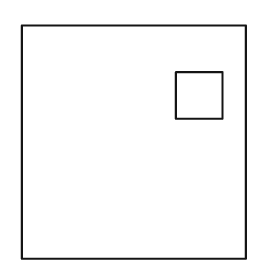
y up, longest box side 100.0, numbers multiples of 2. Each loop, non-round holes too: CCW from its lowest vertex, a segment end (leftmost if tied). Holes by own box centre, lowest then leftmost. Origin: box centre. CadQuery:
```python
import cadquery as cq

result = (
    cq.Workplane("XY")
    .moveTo(-48.0, -50.0)
    .lineTo(48.0, -50.0)
    .lineTo(48.0, 50.0)
    .lineTo(-48.0, 50.0)
    .close()
    .moveTo(18.0, 10.0)
    .lineTo(38.0, 10.0)
    .lineTo(38.0, 30.0)
    .lineTo(18.0, 30.0)
    .close()
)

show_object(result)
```